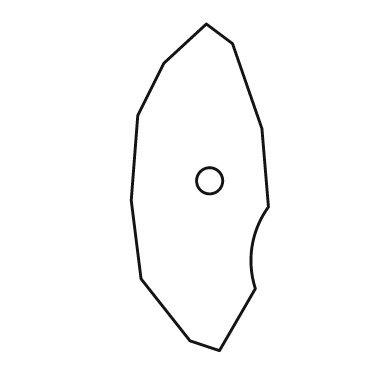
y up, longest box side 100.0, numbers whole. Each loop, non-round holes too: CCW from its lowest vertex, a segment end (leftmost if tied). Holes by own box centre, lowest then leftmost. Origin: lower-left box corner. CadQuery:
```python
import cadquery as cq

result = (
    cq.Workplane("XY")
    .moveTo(27.0, 0.0)
    .lineTo(38.0, 19.0)
    .threePointArc((37.0, 32.0), (42.0, 44.0))
    .lineTo(40.0, 68.0)
    .lineTo(31.0, 94.0)
    .lineTo(23.0, 100.0)
    .lineTo(10.0, 88.0)
    .lineTo(2.0, 72.0)
    .lineTo(0.0, 46.0)
    .lineTo(3.0, 22.0)
    .lineTo(18.0, 3.0)
    .close()
    .moveTo(24.0, 52.0)
    .circle(4.0)
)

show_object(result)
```